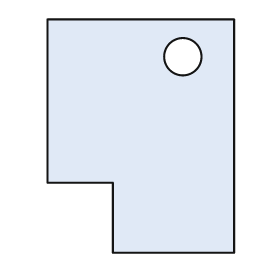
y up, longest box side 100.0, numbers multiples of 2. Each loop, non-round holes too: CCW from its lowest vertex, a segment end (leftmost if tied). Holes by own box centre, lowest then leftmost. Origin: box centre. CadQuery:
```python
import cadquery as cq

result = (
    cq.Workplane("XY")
    .moveTo(-12.0, -50.0)
    .lineTo(40.0, -50.0)
    .lineTo(40.0, 50.0)
    .lineTo(-40.0, 50.0)
    .lineTo(-40.0, -20.0)
    .lineTo(-12.0, -20.0)
    .close()
    .moveTo(18.0, 34.0)
    .circle(8.0)
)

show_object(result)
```